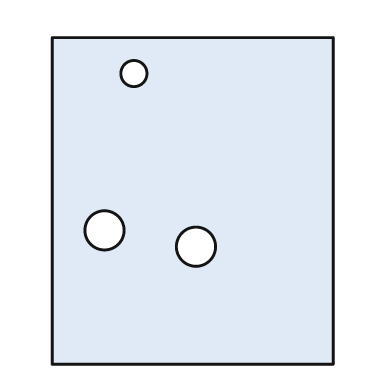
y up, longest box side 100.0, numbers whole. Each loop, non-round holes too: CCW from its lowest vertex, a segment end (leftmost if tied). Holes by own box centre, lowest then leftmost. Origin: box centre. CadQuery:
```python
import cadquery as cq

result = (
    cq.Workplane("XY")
    .moveTo(-43.0, -50.0)
    .lineTo(43.0, -50.0)
    .lineTo(43.0, 50.0)
    .lineTo(-43.0, 50.0)
    .close()
    .moveTo(1.0, -14.0)
    .circle(6.0)
    .moveTo(-27.0, -9.0)
    .circle(6.0)
    .moveTo(-18.0, 39.0)
    .circle(4.0)
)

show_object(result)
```